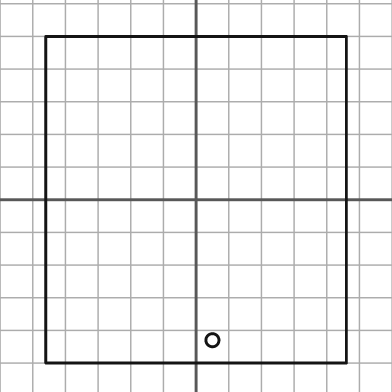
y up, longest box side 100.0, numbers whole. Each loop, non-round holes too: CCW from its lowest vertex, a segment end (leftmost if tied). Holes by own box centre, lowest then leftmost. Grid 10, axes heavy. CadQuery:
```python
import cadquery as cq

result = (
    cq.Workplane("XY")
    .moveTo(-46.0, -50.0)
    .lineTo(46.0, -50.0)
    .lineTo(46.0, 50.0)
    .lineTo(-46.0, 50.0)
    .close()
    .moveTo(5.0, -43.0)
    .circle(2.0)
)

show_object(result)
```